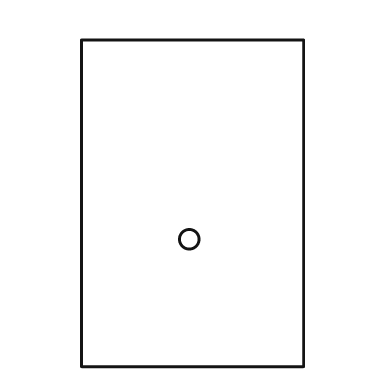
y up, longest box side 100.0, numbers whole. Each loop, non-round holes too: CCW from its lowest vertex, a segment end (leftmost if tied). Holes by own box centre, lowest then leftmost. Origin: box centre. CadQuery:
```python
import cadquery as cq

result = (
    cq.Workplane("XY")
    .moveTo(-34.0, -50.0)
    .lineTo(34.0, -50.0)
    .lineTo(34.0, 50.0)
    .lineTo(-34.0, 50.0)
    .close()
    .moveTo(-1.0, -11.0)
    .circle(3.0)
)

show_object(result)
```